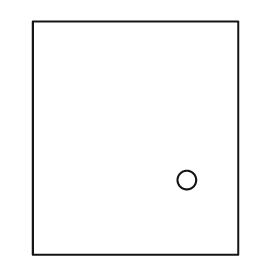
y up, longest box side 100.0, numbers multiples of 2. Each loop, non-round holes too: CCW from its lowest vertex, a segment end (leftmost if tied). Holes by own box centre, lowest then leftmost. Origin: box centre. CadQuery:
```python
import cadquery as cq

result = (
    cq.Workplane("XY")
    .moveTo(-44.0, -50.0)
    .lineTo(44.0, -50.0)
    .lineTo(44.0, 50.0)
    .lineTo(-44.0, 50.0)
    .close()
    .moveTo(22.0, -18.0)
    .circle(4.0)
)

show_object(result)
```